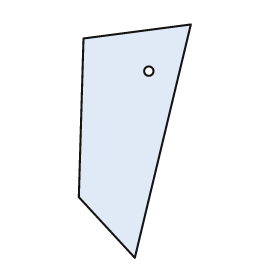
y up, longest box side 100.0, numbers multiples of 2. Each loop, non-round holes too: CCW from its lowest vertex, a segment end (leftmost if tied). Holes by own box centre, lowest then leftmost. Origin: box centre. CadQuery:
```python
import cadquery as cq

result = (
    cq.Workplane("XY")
    .moveTo(0.0, -50.0)
    .lineTo(24.0, 50.0)
    .lineTo(-22.0, 44.0)
    .lineTo(-24.0, -24.0)
    .close()
    .moveTo(6.0, 30.0)
    .circle(2.0)
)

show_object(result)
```